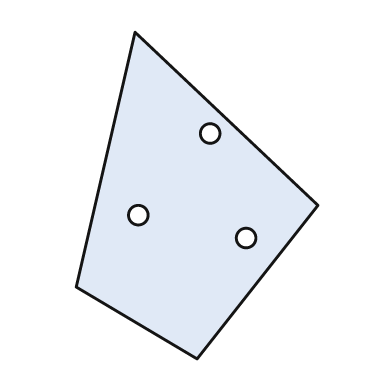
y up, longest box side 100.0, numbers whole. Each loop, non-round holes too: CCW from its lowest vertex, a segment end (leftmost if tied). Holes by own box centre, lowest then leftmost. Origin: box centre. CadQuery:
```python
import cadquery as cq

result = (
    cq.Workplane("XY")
    .moveTo(0.0, -50.0)
    .lineTo(37.0, -3.0)
    .lineTo(-19.0, 50.0)
    .lineTo(-37.0, -28.0)
    .close()
    .moveTo(15.0, -13.0)
    .circle(3.0)
    .moveTo(-18.0, -6.0)
    .circle(3.0)
    .moveTo(4.0, 19.0)
    .circle(3.0)
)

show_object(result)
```